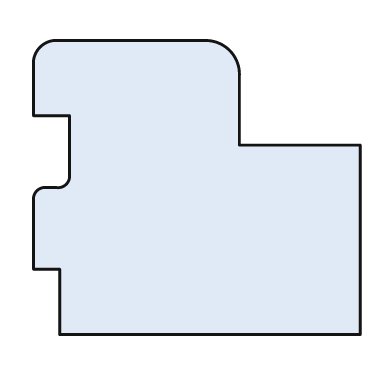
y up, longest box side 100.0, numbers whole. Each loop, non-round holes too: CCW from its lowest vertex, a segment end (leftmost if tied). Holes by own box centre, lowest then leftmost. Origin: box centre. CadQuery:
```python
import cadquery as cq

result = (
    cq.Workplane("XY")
    .moveTo(-42.0, -45.0)
    .lineTo(50.0, -45.0)
    .lineTo(50.0, 13.0)
    .lineTo(13.0, 13.0)
    .lineTo(13.0, 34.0)
    .threePointArc((10.0, 42.0), (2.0, 45.0))
    .lineTo(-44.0, 45.0)
    .threePointArc((-48.0, 43.0), (-50.0, 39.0))
    .lineTo(-50.0, 22.0)
    .lineTo(-39.0, 22.0)
    .lineTo(-39.0, 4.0)
    .threePointArc((-40.0, 1.0), (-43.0, 0.0))
    .lineTo(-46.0, 0.0)
    .threePointArc((-49.0, -1.0), (-50.0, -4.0))
    .lineTo(-50.0, -25.0)
    .lineTo(-42.0, -25.0)
    .close()
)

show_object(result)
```